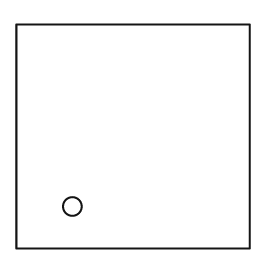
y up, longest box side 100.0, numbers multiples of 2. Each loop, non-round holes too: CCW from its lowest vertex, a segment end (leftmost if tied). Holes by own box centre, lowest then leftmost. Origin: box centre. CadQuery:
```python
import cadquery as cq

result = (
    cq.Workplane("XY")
    .moveTo(-50.0, -48.0)
    .lineTo(50.0, -48.0)
    .lineTo(50.0, 48.0)
    .lineTo(-50.0, 48.0)
    .close()
    .moveTo(-26.0, -30.0)
    .circle(4.0)
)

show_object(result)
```